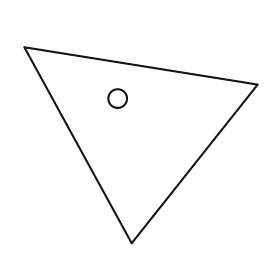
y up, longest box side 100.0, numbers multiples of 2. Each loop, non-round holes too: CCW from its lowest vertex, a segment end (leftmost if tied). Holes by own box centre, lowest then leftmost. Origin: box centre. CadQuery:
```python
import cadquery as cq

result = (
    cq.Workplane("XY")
    .moveTo(-4.0, -42.0)
    .lineTo(50.0, 26.0)
    .lineTo(-50.0, 42.0)
    .close()
    .moveTo(-10.0, 20.0)
    .circle(4.0)
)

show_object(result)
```